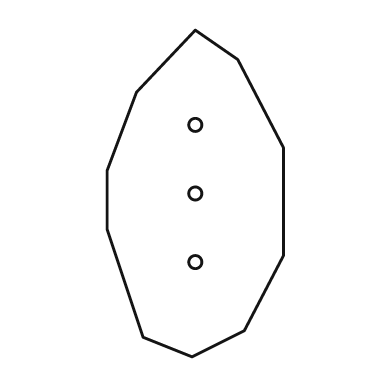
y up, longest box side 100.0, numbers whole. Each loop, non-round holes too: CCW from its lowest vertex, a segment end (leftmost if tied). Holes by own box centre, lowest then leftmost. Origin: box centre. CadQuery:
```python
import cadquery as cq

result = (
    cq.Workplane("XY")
    .moveTo(-1.0, -50.0)
    .lineTo(15.0, -42.0)
    .lineTo(27.0, -19.0)
    .lineTo(27.0, 14.0)
    .lineTo(13.0, 41.0)
    .lineTo(0.0, 50.0)
    .lineTo(-18.0, 31.0)
    .lineTo(-27.0, 7.0)
    .lineTo(-27.0, -11.0)
    .lineTo(-16.0, -44.0)
    .close()
    .moveTo(0.0, -21.0)
    .circle(2.0)
    .moveTo(0.0, 0.0)
    .circle(2.0)
    .moveTo(0.0, 21.0)
    .circle(2.0)
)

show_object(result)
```